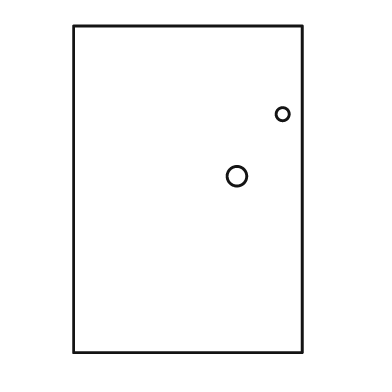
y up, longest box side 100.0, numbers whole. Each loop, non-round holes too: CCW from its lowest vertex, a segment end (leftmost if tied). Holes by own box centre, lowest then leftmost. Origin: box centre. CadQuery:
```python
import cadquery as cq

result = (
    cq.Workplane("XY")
    .moveTo(-35.0, -50.0)
    .lineTo(35.0, -50.0)
    .lineTo(35.0, 50.0)
    .lineTo(-35.0, 50.0)
    .close()
    .moveTo(15.0, 4.0)
    .circle(3.0)
    .moveTo(29.0, 23.0)
    .circle(2.0)
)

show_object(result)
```